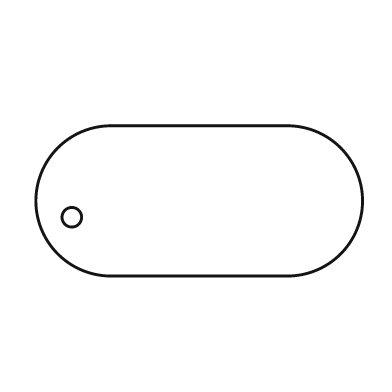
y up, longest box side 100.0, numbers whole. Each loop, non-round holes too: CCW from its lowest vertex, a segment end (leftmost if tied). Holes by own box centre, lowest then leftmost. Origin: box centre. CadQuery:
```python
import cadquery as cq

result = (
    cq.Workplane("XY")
    .moveTo(-27.0, -23.0)
    .lineTo(27.0, -23.0)
    .threePointArc((50.0, 0.0), (27.0, 23.0))
    .lineTo(-27.0, 23.0)
    .threePointArc((-50.0, 0.0), (-27.0, -23.0))
    .close()
    .moveTo(-39.0, -5.0)
    .circle(3.0)
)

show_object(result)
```